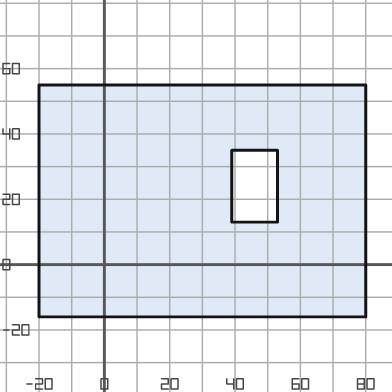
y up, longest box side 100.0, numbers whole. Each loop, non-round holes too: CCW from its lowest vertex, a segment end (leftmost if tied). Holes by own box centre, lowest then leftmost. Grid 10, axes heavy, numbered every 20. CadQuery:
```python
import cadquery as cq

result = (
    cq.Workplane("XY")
    .moveTo(-20.0, -16.0)
    .lineTo(80.0, -16.0)
    .lineTo(80.0, 55.0)
    .lineTo(-20.0, 55.0)
    .close()
    .moveTo(39.0, 13.0)
    .lineTo(53.0, 13.0)
    .lineTo(53.0, 35.0)
    .lineTo(39.0, 35.0)
    .close()
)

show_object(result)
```